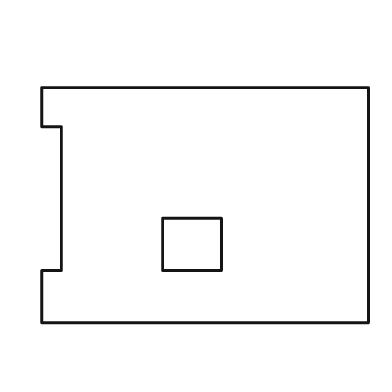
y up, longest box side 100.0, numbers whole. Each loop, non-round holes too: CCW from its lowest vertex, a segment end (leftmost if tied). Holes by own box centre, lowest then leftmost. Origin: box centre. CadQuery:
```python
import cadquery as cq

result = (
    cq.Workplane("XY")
    .moveTo(-50.0, -36.0)
    .lineTo(50.0, -36.0)
    .lineTo(50.0, 36.0)
    .lineTo(-50.0, 36.0)
    .lineTo(-50.0, 24.0)
    .lineTo(-44.0, 24.0)
    .lineTo(-44.0, -20.0)
    .lineTo(-50.0, -20.0)
    .close()
    .moveTo(-13.0, -20.0)
    .lineTo(5.0, -20.0)
    .lineTo(5.0, -4.0)
    .lineTo(-13.0, -4.0)
    .close()
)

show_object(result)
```